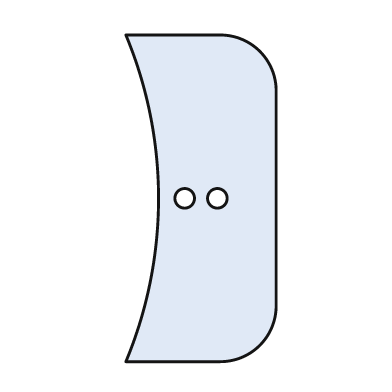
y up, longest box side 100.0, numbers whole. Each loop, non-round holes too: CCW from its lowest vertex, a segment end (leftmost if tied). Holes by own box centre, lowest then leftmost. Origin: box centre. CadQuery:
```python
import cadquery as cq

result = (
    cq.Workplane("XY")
    .moveTo(-23.0, -50.0)
    .lineTo(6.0, -50.0)
    .threePointArc((18.0, -45.0), (23.0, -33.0))
    .lineTo(23.0, 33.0)
    .threePointArc((18.0, 45.0), (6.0, 50.0))
    .lineTo(-23.0, 50.0)
    .threePointArc((-13.0, 0.0), (-23.0, -50.0))
    .close()
    .moveTo(-5.0, 0.0)
    .circle(3.0)
    .moveTo(5.0, 0.0)
    .circle(3.0)
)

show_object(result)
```